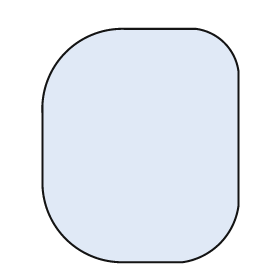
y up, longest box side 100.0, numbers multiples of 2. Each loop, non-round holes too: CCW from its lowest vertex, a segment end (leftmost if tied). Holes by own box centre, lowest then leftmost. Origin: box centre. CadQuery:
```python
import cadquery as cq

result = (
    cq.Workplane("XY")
    .moveTo(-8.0, -50.0)
    .lineTo(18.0, -50.0)
    .threePointArc((34.0, -42.0), (42.0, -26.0))
    .lineTo(42.0, 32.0)
    .threePointArc((36.0, 44.0), (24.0, 50.0))
    .lineTo(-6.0, 50.0)
    .threePointArc((-32.0, 40.0), (-42.0, 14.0))
    .lineTo(-42.0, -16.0)
    .threePointArc((-32.0, -40.0), (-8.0, -50.0))
    .close()
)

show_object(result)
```